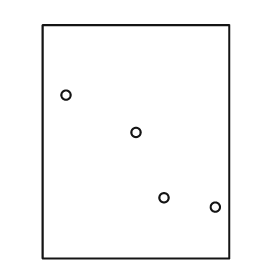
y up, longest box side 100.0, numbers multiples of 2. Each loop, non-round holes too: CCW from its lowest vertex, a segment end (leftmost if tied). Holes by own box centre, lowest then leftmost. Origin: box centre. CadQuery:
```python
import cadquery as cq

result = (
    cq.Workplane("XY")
    .moveTo(-40.0, -50.0)
    .lineTo(40.0, -50.0)
    .lineTo(40.0, 50.0)
    .lineTo(-40.0, 50.0)
    .close()
    .moveTo(34.0, -28.0)
    .circle(2.0)
    .moveTo(12.0, -24.0)
    .circle(2.0)
    .moveTo(0.0, 4.0)
    .circle(2.0)
    .moveTo(-30.0, 20.0)
    .circle(2.0)
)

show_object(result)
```